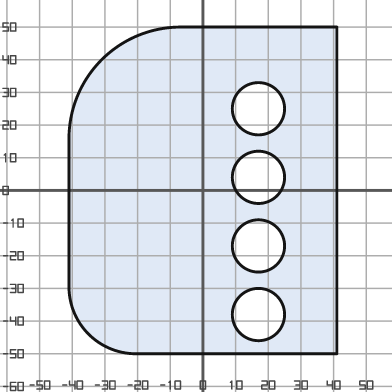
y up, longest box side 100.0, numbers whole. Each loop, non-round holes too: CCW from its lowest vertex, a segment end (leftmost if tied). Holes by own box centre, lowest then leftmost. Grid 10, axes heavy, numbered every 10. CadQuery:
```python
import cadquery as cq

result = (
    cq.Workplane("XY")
    .moveTo(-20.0, -50.0)
    .lineTo(41.0, -50.0)
    .lineTo(41.0, 50.0)
    .lineTo(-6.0, 50.0)
    .threePointArc((-31.0, 40.0), (-41.0, 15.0))
    .lineTo(-41.0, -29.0)
    .threePointArc((-35.0, -44.0), (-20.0, -50.0))
    .close()
    .moveTo(17.0, -38.0)
    .circle(8.0)
    .moveTo(17.0, -17.0)
    .circle(8.0)
    .moveTo(17.0, 4.0)
    .circle(8.0)
    .moveTo(17.0, 25.0)
    .circle(8.0)
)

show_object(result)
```